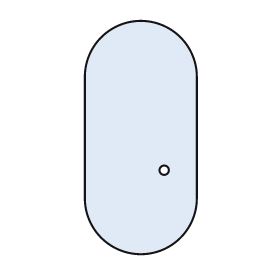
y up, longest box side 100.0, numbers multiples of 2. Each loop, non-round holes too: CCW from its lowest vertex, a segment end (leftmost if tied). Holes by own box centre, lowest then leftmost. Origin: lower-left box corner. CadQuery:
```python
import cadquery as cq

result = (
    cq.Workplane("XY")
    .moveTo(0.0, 24.0)
    .threePointArc((24.0, 0.0), (48.0, 24.0))
    .lineTo(48.0, 76.0)
    .threePointArc((24.0, 100.0), (0.0, 76.0))
    .close()
    .moveTo(34.0, 36.0)
    .circle(2.0)
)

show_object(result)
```